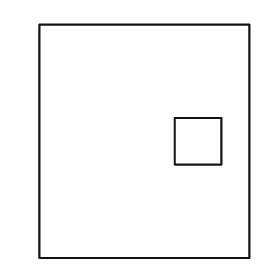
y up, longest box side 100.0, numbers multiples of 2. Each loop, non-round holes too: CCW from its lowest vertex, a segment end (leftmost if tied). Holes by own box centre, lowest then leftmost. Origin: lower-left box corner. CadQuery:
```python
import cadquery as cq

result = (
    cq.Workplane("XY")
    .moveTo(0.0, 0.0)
    .lineTo(90.0, 0.0)
    .lineTo(90.0, 100.0)
    .lineTo(0.0, 100.0)
    .close()
    .moveTo(58.0, 40.0)
    .lineTo(78.0, 40.0)
    .lineTo(78.0, 60.0)
    .lineTo(58.0, 60.0)
    .close()
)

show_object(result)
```